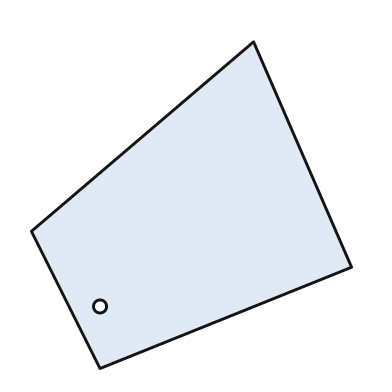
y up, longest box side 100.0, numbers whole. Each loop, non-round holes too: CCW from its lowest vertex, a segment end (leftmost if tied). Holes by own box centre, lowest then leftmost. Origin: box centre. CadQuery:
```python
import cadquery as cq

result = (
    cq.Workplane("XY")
    .moveTo(-28.0, -50.0)
    .lineTo(49.0, -19.0)
    .lineTo(19.0, 50.0)
    .lineTo(-49.0, -8.0)
    .close()
    .moveTo(-28.0, -31.0)
    .circle(2.0)
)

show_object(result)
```